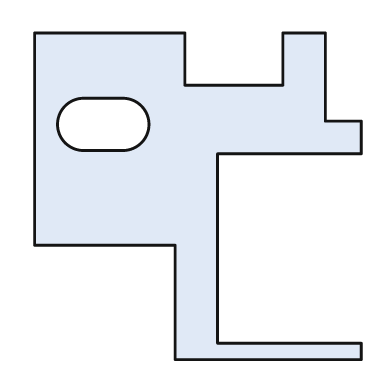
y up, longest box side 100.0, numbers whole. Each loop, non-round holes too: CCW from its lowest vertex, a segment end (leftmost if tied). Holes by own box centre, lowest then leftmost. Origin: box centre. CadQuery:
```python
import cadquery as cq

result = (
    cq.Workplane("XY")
    .moveTo(-7.0, -50.0)
    .lineTo(50.0, -50.0)
    .lineTo(50.0, -45.0)
    .lineTo(6.0, -45.0)
    .lineTo(6.0, 13.0)
    .lineTo(50.0, 13.0)
    .lineTo(50.0, 23.0)
    .lineTo(39.0, 23.0)
    .lineTo(39.0, 50.0)
    .lineTo(26.0, 50.0)
    .lineTo(26.0, 34.0)
    .lineTo(-4.0, 34.0)
    .lineTo(-4.0, 50.0)
    .lineTo(-50.0, 50.0)
    .lineTo(-50.0, -15.0)
    .lineTo(-7.0, -15.0)
    .close()
    .moveTo(-35.0, 14.0)
    .lineTo(-23.0, 14.0)
    .threePointArc((-15.0, 22.0), (-23.0, 30.0))
    .lineTo(-35.0, 30.0)
    .threePointArc((-43.0, 22.0), (-35.0, 14.0))
    .close()
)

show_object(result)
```